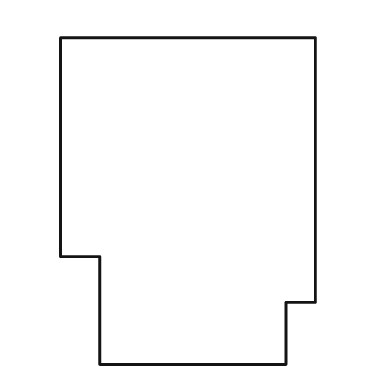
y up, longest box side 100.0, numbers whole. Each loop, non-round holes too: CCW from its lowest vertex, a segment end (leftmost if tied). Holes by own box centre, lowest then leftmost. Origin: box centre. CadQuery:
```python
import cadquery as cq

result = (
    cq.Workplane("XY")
    .moveTo(-27.0, -50.0)
    .lineTo(30.0, -50.0)
    .lineTo(30.0, -31.0)
    .lineTo(39.0, -31.0)
    .lineTo(39.0, 50.0)
    .lineTo(-39.0, 50.0)
    .lineTo(-39.0, -17.0)
    .lineTo(-27.0, -17.0)
    .close()
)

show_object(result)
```